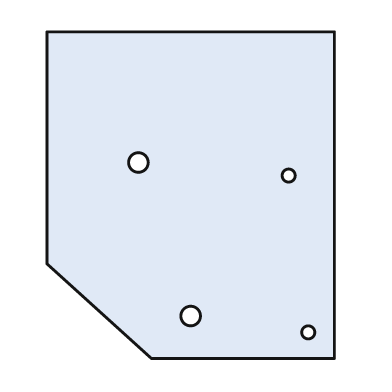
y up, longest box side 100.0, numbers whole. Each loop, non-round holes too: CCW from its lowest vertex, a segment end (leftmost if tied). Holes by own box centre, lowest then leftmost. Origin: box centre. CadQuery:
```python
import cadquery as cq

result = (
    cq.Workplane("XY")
    .moveTo(-12.0, -50.0)
    .lineTo(44.0, -50.0)
    .lineTo(44.0, 50.0)
    .lineTo(-44.0, 50.0)
    .lineTo(-44.0, -21.0)
    .close()
    .moveTo(36.0, -42.0)
    .circle(2.0)
    .moveTo(0.0, -37.0)
    .circle(3.0)
    .moveTo(30.0, 6.0)
    .circle(2.0)
    .moveTo(-16.0, 10.0)
    .circle(3.0)
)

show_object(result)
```